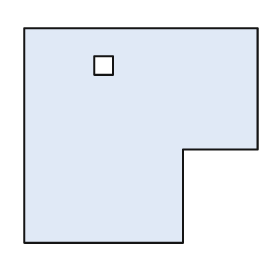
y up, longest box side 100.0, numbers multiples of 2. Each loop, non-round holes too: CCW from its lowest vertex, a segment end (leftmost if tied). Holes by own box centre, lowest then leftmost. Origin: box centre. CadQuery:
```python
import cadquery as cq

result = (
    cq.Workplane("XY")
    .moveTo(-50.0, -46.0)
    .lineTo(18.0, -46.0)
    .lineTo(18.0, -6.0)
    .lineTo(50.0, -6.0)
    .lineTo(50.0, 46.0)
    .lineTo(-50.0, 46.0)
    .close()
    .moveTo(-20.0, 26.0)
    .lineTo(-12.0, 26.0)
    .lineTo(-12.0, 34.0)
    .lineTo(-20.0, 34.0)
    .close()
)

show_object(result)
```